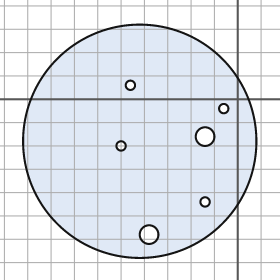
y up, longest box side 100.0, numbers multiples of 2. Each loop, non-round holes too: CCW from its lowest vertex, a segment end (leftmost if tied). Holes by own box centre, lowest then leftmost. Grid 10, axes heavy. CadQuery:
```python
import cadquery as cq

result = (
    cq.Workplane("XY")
    .moveTo(-42.0, -18.0)
    .circle(50.0)
    .moveTo(-38.0, -58.0)
    .circle(4.0)
    .moveTo(-14.0, -44.0)
    .circle(2.0)
    .moveTo(-50.0, -20.0)
    .circle(2.0)
    .moveTo(-14.0, -16.0)
    .circle(4.0)
    .moveTo(-6.0, -4.0)
    .circle(2.0)
    .moveTo(-46.0, 6.0)
    .circle(2.0)
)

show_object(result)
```